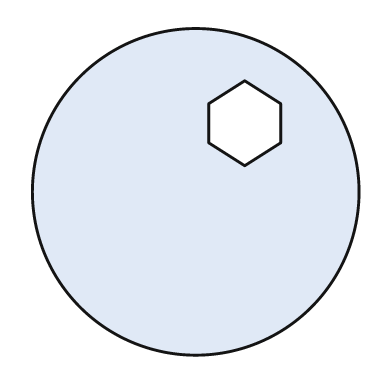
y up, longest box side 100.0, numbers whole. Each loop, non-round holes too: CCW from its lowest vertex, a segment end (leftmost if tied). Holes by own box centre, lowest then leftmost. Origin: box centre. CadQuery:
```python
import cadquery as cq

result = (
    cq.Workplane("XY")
    .moveTo(0.0, 0.0)
    .circle(50.0)
    .moveTo(15.0, 8.0)
    .lineTo(26.0, 15.0)
    .lineTo(26.0, 27.0)
    .lineTo(15.0, 34.0)
    .lineTo(4.0, 27.0)
    .lineTo(4.0, 15.0)
    .close()
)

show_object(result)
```